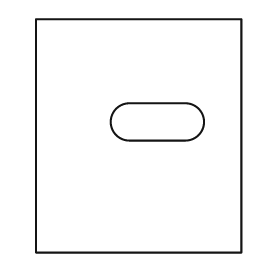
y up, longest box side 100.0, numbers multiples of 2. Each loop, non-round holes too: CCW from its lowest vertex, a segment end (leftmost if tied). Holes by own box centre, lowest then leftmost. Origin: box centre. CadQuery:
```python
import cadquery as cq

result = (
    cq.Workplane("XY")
    .moveTo(-44.0, -50.0)
    .lineTo(44.0, -50.0)
    .lineTo(44.0, 50.0)
    .lineTo(-44.0, 50.0)
    .close()
    .moveTo(-4.0, -2.0)
    .lineTo(20.0, -2.0)
    .threePointArc((28.0, 6.0), (20.0, 14.0))
    .lineTo(-4.0, 14.0)
    .threePointArc((-12.0, 6.0), (-4.0, -2.0))
    .close()
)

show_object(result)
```